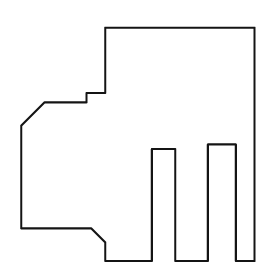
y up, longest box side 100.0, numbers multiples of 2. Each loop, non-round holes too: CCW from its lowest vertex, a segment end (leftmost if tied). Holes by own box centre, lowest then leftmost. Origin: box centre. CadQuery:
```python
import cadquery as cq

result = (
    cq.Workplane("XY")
    .moveTo(-14.0, -50.0)
    .lineTo(6.0, -50.0)
    .lineTo(6.0, -2.0)
    .lineTo(16.0, -2.0)
    .lineTo(16.0, -50.0)
    .lineTo(30.0, -50.0)
    .lineTo(30.0, 0.0)
    .lineTo(42.0, 0.0)
    .lineTo(42.0, -50.0)
    .lineTo(50.0, -50.0)
    .lineTo(50.0, 50.0)
    .lineTo(-14.0, 50.0)
    .lineTo(-14.0, 22.0)
    .lineTo(-22.0, 22.0)
    .lineTo(-22.0, 18.0)
    .lineTo(-40.0, 18.0)
    .lineTo(-50.0, 8.0)
    .lineTo(-50.0, -36.0)
    .lineTo(-20.0, -36.0)
    .lineTo(-14.0, -42.0)
    .close()
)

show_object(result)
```